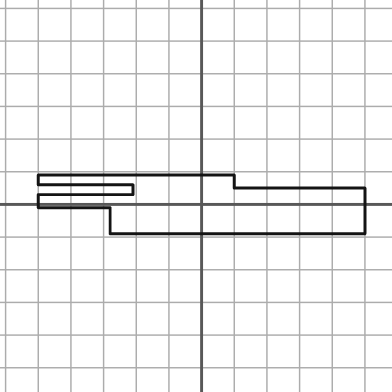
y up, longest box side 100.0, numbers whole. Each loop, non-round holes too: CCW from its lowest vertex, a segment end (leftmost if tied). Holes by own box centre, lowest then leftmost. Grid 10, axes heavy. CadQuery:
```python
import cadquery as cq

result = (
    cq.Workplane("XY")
    .moveTo(-28.0, -9.0)
    .lineTo(50.0, -9.0)
    .lineTo(50.0, 5.0)
    .lineTo(10.0, 5.0)
    .lineTo(10.0, 9.0)
    .lineTo(-50.0, 9.0)
    .lineTo(-50.0, 6.0)
    .lineTo(-21.0, 6.0)
    .lineTo(-21.0, 3.0)
    .lineTo(-50.0, 3.0)
    .lineTo(-50.0, -1.0)
    .lineTo(-28.0, -1.0)
    .close()
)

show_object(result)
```